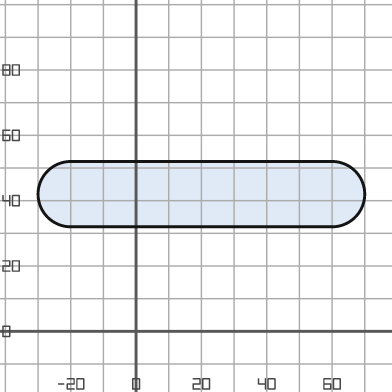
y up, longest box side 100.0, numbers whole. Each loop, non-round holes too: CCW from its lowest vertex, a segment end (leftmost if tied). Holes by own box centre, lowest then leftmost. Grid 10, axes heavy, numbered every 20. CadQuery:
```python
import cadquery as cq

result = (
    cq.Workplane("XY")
    .moveTo(-20.0, 32.0)
    .lineTo(60.0, 32.0)
    .threePointArc((70.0, 42.0), (60.0, 52.0))
    .lineTo(-20.0, 52.0)
    .threePointArc((-30.0, 42.0), (-20.0, 32.0))
    .close()
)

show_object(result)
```